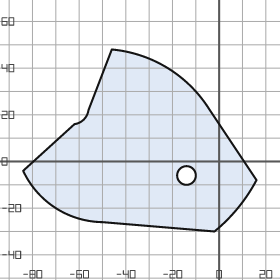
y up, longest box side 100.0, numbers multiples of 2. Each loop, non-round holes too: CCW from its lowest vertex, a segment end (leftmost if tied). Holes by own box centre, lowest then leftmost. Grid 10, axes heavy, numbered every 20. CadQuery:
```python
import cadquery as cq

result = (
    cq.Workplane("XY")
    .moveTo(-2.0, -30.0)
    .threePointArc((8.0, -20.0), (16.0, -8.0))
    .lineTo(-4.0, 22.0)
    .threePointArc((-22.0, 40.0), (-46.0, 48.0))
    .lineTo(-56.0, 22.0)
    .threePointArc((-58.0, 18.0), (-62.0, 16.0))
    .lineTo(-84.0, -4.0)
    .threePointArc((-70.0, -20.0), (-50.0, -26.0))
    .close()
    .moveTo(-14.0, -6.0)
    .circle(4.0)
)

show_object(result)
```